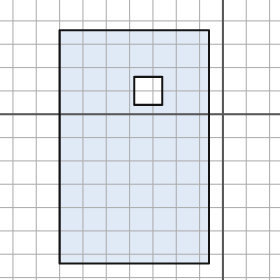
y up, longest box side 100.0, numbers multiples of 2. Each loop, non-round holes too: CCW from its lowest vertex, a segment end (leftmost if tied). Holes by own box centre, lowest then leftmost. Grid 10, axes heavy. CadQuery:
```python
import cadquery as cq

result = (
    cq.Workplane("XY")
    .moveTo(-70.0, -64.0)
    .lineTo(-6.0, -64.0)
    .lineTo(-6.0, 36.0)
    .lineTo(-70.0, 36.0)
    .close()
    .moveTo(-38.0, 4.0)
    .lineTo(-26.0, 4.0)
    .lineTo(-26.0, 16.0)
    .lineTo(-38.0, 16.0)
    .close()
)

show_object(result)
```